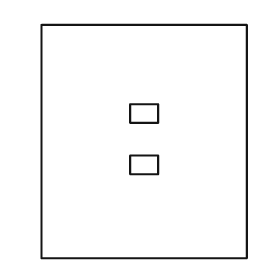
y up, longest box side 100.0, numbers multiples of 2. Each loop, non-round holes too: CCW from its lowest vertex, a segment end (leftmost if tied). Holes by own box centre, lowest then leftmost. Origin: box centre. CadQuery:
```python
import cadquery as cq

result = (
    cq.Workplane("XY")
    .moveTo(-44.0, -50.0)
    .lineTo(44.0, -50.0)
    .lineTo(44.0, 50.0)
    .lineTo(-44.0, 50.0)
    .close()
    .moveTo(-6.0, -14.0)
    .lineTo(6.0, -14.0)
    .lineTo(6.0, -6.0)
    .lineTo(-6.0, -6.0)
    .close()
    .moveTo(-6.0, 8.0)
    .lineTo(6.0, 8.0)
    .lineTo(6.0, 16.0)
    .lineTo(-6.0, 16.0)
    .close()
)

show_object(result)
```